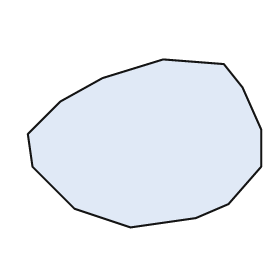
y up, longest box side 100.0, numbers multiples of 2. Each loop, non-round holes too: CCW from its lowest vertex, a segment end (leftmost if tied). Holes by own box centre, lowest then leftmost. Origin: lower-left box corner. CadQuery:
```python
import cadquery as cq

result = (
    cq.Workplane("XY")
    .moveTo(44.0, 0.0)
    .lineTo(72.0, 4.0)
    .lineTo(86.0, 10.0)
    .lineTo(100.0, 26.0)
    .lineTo(100.0, 42.0)
    .lineTo(92.0, 60.0)
    .lineTo(84.0, 70.0)
    .lineTo(58.0, 72.0)
    .lineTo(32.0, 64.0)
    .lineTo(14.0, 54.0)
    .lineTo(0.0, 40.0)
    .lineTo(2.0, 26.0)
    .lineTo(20.0, 8.0)
    .close()
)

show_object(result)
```